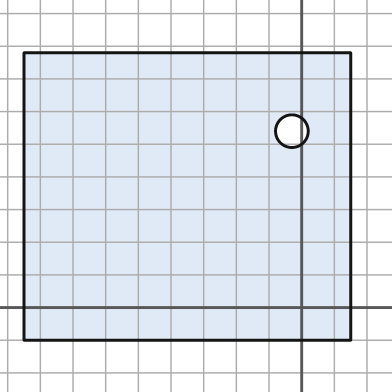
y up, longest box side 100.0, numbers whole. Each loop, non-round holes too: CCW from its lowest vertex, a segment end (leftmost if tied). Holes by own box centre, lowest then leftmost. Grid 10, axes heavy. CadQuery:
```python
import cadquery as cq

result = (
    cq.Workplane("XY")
    .moveTo(-85.0, -10.0)
    .lineTo(15.0, -10.0)
    .lineTo(15.0, 78.0)
    .lineTo(-85.0, 78.0)
    .close()
    .moveTo(-3.0, 54.0)
    .circle(5.0)
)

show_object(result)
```